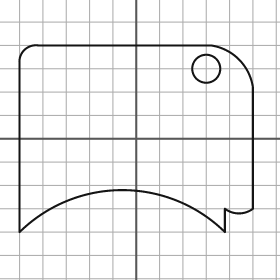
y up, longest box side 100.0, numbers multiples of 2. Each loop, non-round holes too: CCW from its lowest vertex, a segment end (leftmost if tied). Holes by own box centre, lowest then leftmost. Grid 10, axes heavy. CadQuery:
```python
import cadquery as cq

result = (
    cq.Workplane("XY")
    .moveTo(-50.0, -40.0)
    .threePointArc((-6.0, -22.0), (38.0, -40.0))
    .lineTo(38.0, -30.0)
    .threePointArc((44.0, -32.0), (50.0, -30.0))
    .lineTo(50.0, 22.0)
    .threePointArc((44.0, 34.0), (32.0, 40.0))
    .lineTo(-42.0, 40.0)
    .threePointArc((-48.0, 38.0), (-50.0, 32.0))
    .close()
    .moveTo(30.0, 30.0)
    .circle(6.0)
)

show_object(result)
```